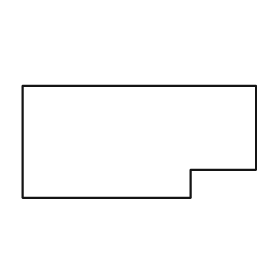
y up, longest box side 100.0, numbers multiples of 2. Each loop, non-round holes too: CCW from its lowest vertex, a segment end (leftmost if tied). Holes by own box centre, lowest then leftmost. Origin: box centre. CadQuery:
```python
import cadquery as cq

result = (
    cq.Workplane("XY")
    .moveTo(-50.0, -24.0)
    .lineTo(22.0, -24.0)
    .lineTo(22.0, -12.0)
    .lineTo(50.0, -12.0)
    .lineTo(50.0, 24.0)
    .lineTo(-50.0, 24.0)
    .close()
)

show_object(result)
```